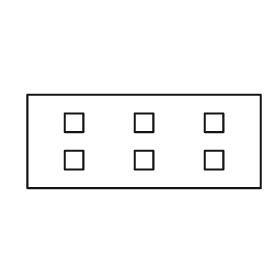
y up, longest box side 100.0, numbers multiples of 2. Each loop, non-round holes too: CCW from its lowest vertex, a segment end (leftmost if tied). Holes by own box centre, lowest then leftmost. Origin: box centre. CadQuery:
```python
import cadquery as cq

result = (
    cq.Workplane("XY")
    .moveTo(-50.0, -20.0)
    .lineTo(50.0, -20.0)
    .lineTo(50.0, 20.0)
    .lineTo(-50.0, 20.0)
    .close()
    .moveTo(-34.0, -12.0)
    .lineTo(-26.0, -12.0)
    .lineTo(-26.0, -4.0)
    .lineTo(-34.0, -4.0)
    .close()
    .moveTo(-4.0, -12.0)
    .lineTo(4.0, -12.0)
    .lineTo(4.0, -4.0)
    .lineTo(-4.0, -4.0)
    .close()
    .moveTo(26.0, -12.0)
    .lineTo(34.0, -12.0)
    .lineTo(34.0, -4.0)
    .lineTo(26.0, -4.0)
    .close()
    .moveTo(-34.0, 4.0)
    .lineTo(-26.0, 4.0)
    .lineTo(-26.0, 12.0)
    .lineTo(-34.0, 12.0)
    .close()
    .moveTo(-4.0, 4.0)
    .lineTo(4.0, 4.0)
    .lineTo(4.0, 12.0)
    .lineTo(-4.0, 12.0)
    .close()
    .moveTo(26.0, 4.0)
    .lineTo(34.0, 4.0)
    .lineTo(34.0, 12.0)
    .lineTo(26.0, 12.0)
    .close()
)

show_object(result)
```